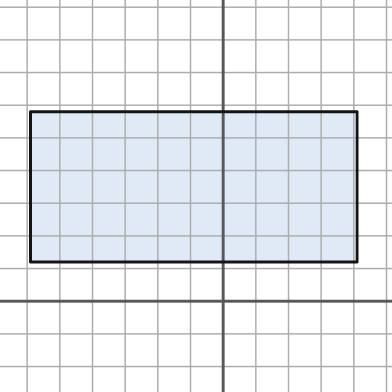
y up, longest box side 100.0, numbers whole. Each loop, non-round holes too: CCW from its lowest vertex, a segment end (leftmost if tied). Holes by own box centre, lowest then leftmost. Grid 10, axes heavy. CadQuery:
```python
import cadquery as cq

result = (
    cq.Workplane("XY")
    .moveTo(-59.0, 12.0)
    .lineTo(41.0, 12.0)
    .lineTo(41.0, 58.0)
    .lineTo(-59.0, 58.0)
    .close()
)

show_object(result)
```